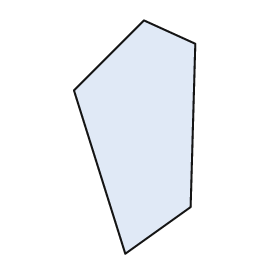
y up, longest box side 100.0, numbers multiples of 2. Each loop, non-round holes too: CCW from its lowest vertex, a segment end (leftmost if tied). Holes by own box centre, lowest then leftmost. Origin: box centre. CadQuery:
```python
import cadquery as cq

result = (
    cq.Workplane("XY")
    .moveTo(-4.0, -50.0)
    .lineTo(24.0, -30.0)
    .lineTo(26.0, 40.0)
    .lineTo(4.0, 50.0)
    .lineTo(-26.0, 20.0)
    .close()
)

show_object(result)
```